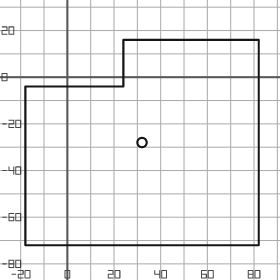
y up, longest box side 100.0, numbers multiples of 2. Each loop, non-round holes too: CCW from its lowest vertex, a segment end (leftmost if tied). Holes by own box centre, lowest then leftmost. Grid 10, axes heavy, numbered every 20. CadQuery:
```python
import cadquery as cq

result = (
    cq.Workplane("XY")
    .moveTo(-18.0, -72.0)
    .lineTo(82.0, -72.0)
    .lineTo(82.0, 16.0)
    .lineTo(24.0, 16.0)
    .lineTo(24.0, -4.0)
    .lineTo(-18.0, -4.0)
    .close()
    .moveTo(32.0, -28.0)
    .circle(2.0)
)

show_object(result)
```